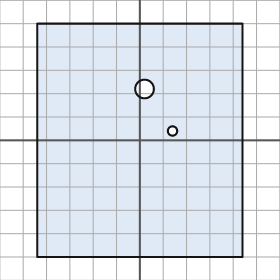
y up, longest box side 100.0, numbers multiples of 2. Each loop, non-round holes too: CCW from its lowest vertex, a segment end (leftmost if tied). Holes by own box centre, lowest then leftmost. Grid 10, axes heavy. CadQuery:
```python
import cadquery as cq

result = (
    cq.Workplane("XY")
    .moveTo(-44.0, -50.0)
    .lineTo(44.0, -50.0)
    .lineTo(44.0, 50.0)
    .lineTo(-44.0, 50.0)
    .close()
    .moveTo(14.0, 4.0)
    .circle(2.0)
    .moveTo(2.0, 22.0)
    .circle(4.0)
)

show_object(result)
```